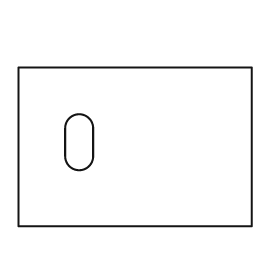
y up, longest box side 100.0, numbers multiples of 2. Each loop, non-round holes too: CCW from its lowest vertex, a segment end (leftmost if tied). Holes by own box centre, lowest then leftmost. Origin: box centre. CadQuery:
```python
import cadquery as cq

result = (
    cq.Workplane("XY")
    .moveTo(-50.0, -34.0)
    .lineTo(50.0, -34.0)
    .lineTo(50.0, 34.0)
    .lineTo(-50.0, 34.0)
    .close()
    .moveTo(-30.0, -4.0)
    .threePointArc((-24.0, -10.0), (-18.0, -4.0))
    .lineTo(-18.0, 8.0)
    .threePointArc((-24.0, 14.0), (-30.0, 8.0))
    .close()
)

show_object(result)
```